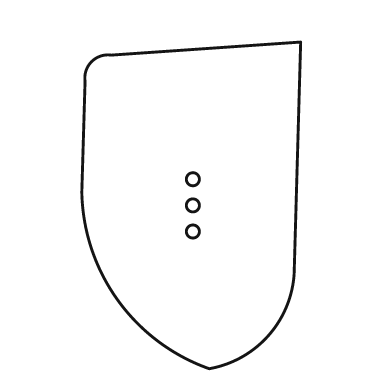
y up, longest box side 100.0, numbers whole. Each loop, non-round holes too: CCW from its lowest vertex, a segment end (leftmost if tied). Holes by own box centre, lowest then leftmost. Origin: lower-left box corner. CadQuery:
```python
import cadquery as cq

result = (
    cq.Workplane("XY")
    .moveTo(39.0, 0.0)
    .threePointArc((57.0, 10.0), (65.0, 29.0))
    .lineTo(67.0, 100.0)
    .lineTo(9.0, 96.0)
    .threePointArc((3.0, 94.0), (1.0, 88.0))
    .lineTo(0.0, 54.0)
    .threePointArc((11.0, 21.0), (39.0, 0.0))
    .close()
    .moveTo(34.0, 42.0)
    .circle(2.0)
    .moveTo(34.0, 50.0)
    .circle(2.0)
    .moveTo(34.0, 58.0)
    .circle(2.0)
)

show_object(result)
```